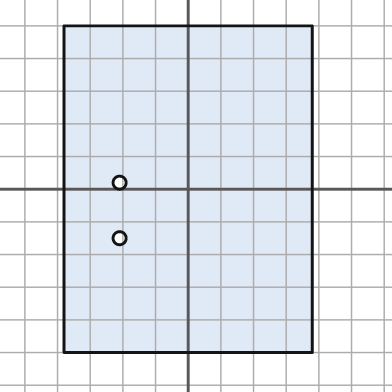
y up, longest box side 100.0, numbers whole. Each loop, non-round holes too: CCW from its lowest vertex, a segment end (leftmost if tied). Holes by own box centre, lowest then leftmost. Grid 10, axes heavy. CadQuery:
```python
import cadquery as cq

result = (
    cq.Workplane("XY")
    .moveTo(-38.0, -50.0)
    .lineTo(38.0, -50.0)
    .lineTo(38.0, 50.0)
    .lineTo(-38.0, 50.0)
    .close()
    .moveTo(-21.0, -15.0)
    .circle(2.0)
    .moveTo(-21.0, 2.0)
    .circle(2.0)
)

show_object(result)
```